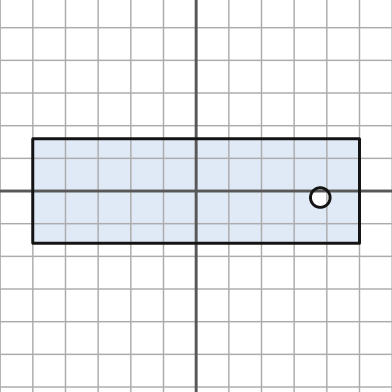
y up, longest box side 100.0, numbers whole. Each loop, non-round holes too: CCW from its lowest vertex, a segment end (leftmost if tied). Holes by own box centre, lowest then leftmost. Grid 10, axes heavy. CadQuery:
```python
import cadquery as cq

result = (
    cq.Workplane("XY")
    .moveTo(-50.0, -16.0)
    .lineTo(50.0, -16.0)
    .lineTo(50.0, 16.0)
    .lineTo(-50.0, 16.0)
    .close()
    .moveTo(38.0, -2.0)
    .circle(3.0)
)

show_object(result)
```